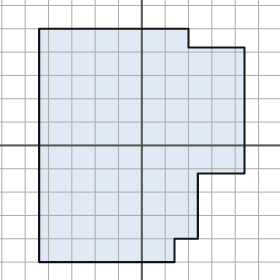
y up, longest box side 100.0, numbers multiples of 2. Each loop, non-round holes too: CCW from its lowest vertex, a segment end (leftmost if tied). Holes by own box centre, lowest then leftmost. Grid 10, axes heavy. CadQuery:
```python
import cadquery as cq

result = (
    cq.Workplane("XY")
    .moveTo(-44.0, -50.0)
    .lineTo(14.0, -50.0)
    .lineTo(14.0, -40.0)
    .lineTo(24.0, -40.0)
    .lineTo(24.0, -12.0)
    .lineTo(44.0, -12.0)
    .lineTo(44.0, 42.0)
    .lineTo(20.0, 42.0)
    .lineTo(20.0, 50.0)
    .lineTo(-44.0, 50.0)
    .close()
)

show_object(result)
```